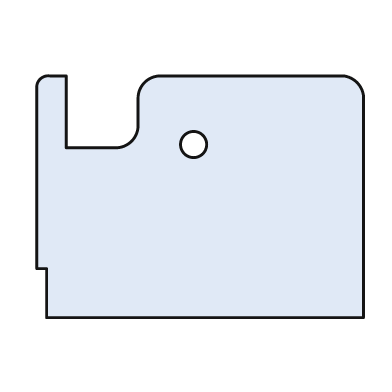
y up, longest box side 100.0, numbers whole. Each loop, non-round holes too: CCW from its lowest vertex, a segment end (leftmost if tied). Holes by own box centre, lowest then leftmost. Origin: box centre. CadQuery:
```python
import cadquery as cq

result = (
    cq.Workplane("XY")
    .moveTo(-47.0, -37.0)
    .lineTo(50.0, -37.0)
    .lineTo(50.0, 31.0)
    .threePointArc((48.0, 35.0), (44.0, 37.0))
    .lineTo(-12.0, 37.0)
    .threePointArc((-17.0, 35.0), (-19.0, 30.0))
    .lineTo(-19.0, 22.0)
    .threePointArc((-21.0, 17.0), (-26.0, 15.0))
    .lineTo(-41.0, 15.0)
    .lineTo(-41.0, 37.0)
    .lineTo(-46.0, 37.0)
    .threePointArc((-49.0, 36.0), (-50.0, 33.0))
    .lineTo(-50.0, -22.0)
    .lineTo(-47.0, -22.0)
    .close()
    .moveTo(-2.0, 16.0)
    .circle(4.0)
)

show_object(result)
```